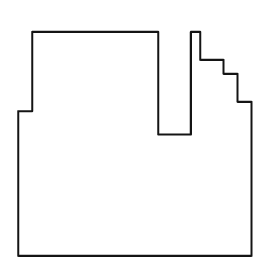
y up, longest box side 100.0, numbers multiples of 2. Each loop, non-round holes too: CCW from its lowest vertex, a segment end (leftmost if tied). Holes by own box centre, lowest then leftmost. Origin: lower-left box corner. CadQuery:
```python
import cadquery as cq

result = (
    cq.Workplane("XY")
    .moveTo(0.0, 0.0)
    .lineTo(100.0, 0.0)
    .lineTo(100.0, 66.0)
    .lineTo(94.0, 66.0)
    .lineTo(94.0, 78.0)
    .lineTo(88.0, 78.0)
    .lineTo(88.0, 84.0)
    .lineTo(78.0, 84.0)
    .lineTo(78.0, 96.0)
    .lineTo(74.0, 96.0)
    .lineTo(74.0, 52.0)
    .lineTo(60.0, 52.0)
    .lineTo(60.0, 96.0)
    .lineTo(6.0, 96.0)
    .lineTo(6.0, 62.0)
    .lineTo(0.0, 62.0)
    .close()
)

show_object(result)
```